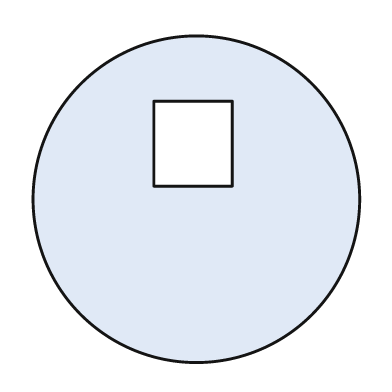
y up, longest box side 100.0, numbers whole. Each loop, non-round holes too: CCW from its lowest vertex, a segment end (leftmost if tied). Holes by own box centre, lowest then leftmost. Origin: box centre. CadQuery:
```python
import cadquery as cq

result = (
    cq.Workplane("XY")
    .moveTo(0.0, 0.0)
    .circle(50.0)
    .moveTo(-13.0, 4.0)
    .lineTo(11.0, 4.0)
    .lineTo(11.0, 30.0)
    .lineTo(-13.0, 30.0)
    .close()
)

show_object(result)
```